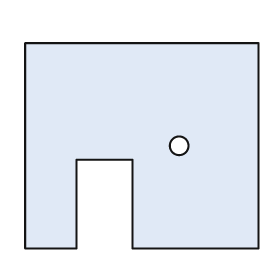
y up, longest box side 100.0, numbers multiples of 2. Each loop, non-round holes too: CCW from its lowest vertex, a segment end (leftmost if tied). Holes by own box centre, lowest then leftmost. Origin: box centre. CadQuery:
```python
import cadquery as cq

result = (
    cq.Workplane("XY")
    .moveTo(-50.0, -44.0)
    .lineTo(-28.0, -44.0)
    .lineTo(-28.0, -6.0)
    .lineTo(-4.0, -6.0)
    .lineTo(-4.0, -44.0)
    .lineTo(50.0, -44.0)
    .lineTo(50.0, 44.0)
    .lineTo(-50.0, 44.0)
    .close()
    .moveTo(16.0, 0.0)
    .circle(4.0)
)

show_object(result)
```